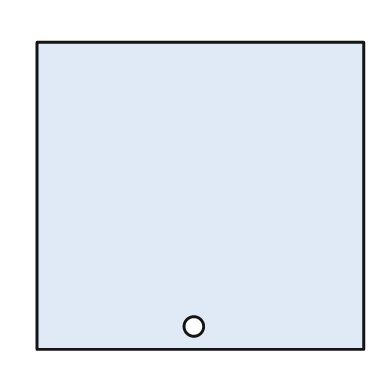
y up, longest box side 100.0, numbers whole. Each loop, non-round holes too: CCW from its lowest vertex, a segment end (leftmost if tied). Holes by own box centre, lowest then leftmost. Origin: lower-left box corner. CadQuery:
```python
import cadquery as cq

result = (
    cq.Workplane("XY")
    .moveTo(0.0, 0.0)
    .lineTo(100.0, 0.0)
    .lineTo(100.0, 94.0)
    .lineTo(0.0, 94.0)
    .close()
    .moveTo(48.0, 7.0)
    .circle(3.0)
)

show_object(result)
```